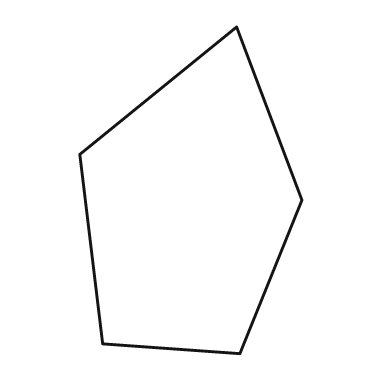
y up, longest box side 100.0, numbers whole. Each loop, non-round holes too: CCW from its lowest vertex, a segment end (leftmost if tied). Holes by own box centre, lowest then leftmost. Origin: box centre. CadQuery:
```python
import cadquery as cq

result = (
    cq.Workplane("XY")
    .moveTo(15.0, -50.0)
    .lineTo(34.0, -3.0)
    .lineTo(14.0, 50.0)
    .lineTo(-34.0, 11.0)
    .lineTo(-27.0, -47.0)
    .close()
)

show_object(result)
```